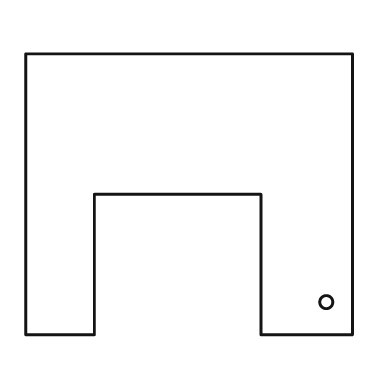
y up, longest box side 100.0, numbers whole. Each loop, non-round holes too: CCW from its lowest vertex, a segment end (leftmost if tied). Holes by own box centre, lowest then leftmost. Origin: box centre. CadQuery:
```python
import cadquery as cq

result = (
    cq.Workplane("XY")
    .moveTo(-50.0, -43.0)
    .lineTo(-29.0, -43.0)
    .lineTo(-29.0, 0.0)
    .lineTo(22.0, 0.0)
    .lineTo(22.0, -43.0)
    .lineTo(50.0, -43.0)
    .lineTo(50.0, 43.0)
    .lineTo(-50.0, 43.0)
    .close()
    .moveTo(42.0, -33.0)
    .circle(2.0)
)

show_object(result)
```